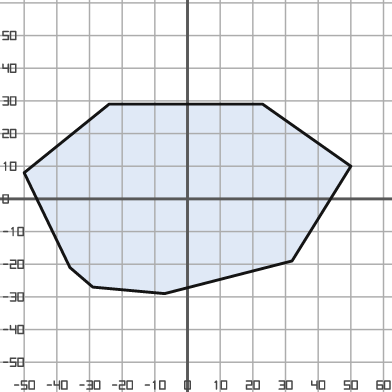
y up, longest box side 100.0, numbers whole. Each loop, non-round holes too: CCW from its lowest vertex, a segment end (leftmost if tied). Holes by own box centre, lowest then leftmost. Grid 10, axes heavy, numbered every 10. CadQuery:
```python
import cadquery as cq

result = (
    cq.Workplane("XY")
    .moveTo(-7.0, -29.0)
    .lineTo(32.0, -19.0)
    .lineTo(50.0, 10.0)
    .lineTo(23.0, 29.0)
    .lineTo(-24.0, 29.0)
    .lineTo(-50.0, 8.0)
    .lineTo(-36.0, -21.0)
    .lineTo(-29.0, -27.0)
    .close()
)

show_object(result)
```